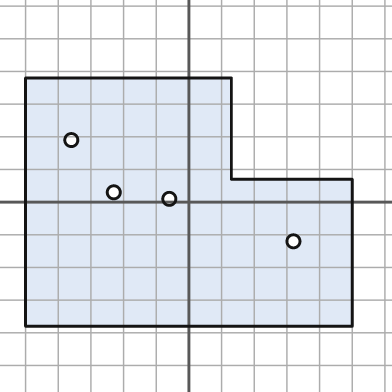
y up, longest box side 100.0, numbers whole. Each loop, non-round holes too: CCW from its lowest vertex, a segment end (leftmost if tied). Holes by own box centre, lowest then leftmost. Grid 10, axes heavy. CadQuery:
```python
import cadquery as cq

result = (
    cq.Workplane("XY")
    .moveTo(-50.0, -38.0)
    .lineTo(50.0, -38.0)
    .lineTo(50.0, 7.0)
    .lineTo(13.0, 7.0)
    .lineTo(13.0, 38.0)
    .lineTo(-50.0, 38.0)
    .close()
    .moveTo(32.0, -12.0)
    .circle(2.0)
    .moveTo(-6.0, 1.0)
    .circle(2.0)
    .moveTo(-23.0, 3.0)
    .circle(2.0)
    .moveTo(-36.0, 19.0)
    .circle(2.0)
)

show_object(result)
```